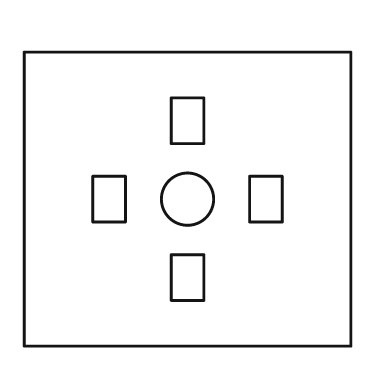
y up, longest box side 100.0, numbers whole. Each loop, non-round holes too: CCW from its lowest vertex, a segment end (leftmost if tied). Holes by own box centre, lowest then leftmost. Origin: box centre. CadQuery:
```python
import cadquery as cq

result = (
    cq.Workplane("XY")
    .moveTo(-50.0, -45.0)
    .lineTo(50.0, -45.0)
    .lineTo(50.0, 45.0)
    .lineTo(-50.0, 45.0)
    .close()
    .moveTo(-5.0, -31.0)
    .lineTo(5.0, -31.0)
    .lineTo(5.0, -17.0)
    .lineTo(-5.0, -17.0)
    .close()
    .moveTo(-29.0, -7.0)
    .lineTo(-19.0, -7.0)
    .lineTo(-19.0, 7.0)
    .lineTo(-29.0, 7.0)
    .close()
    .moveTo(0.0, 0.0)
    .circle(8.0)
    .moveTo(19.0, -7.0)
    .lineTo(29.0, -7.0)
    .lineTo(29.0, 7.0)
    .lineTo(19.0, 7.0)
    .close()
    .moveTo(-5.0, 17.0)
    .lineTo(5.0, 17.0)
    .lineTo(5.0, 31.0)
    .lineTo(-5.0, 31.0)
    .close()
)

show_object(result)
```